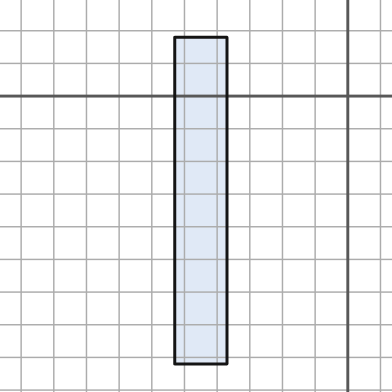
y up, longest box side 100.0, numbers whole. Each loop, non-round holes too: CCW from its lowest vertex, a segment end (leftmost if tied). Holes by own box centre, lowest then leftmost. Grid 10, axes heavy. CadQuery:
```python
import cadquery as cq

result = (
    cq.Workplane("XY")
    .moveTo(-53.0, -82.0)
    .lineTo(-37.0, -82.0)
    .lineTo(-37.0, 18.0)
    .lineTo(-53.0, 18.0)
    .close()
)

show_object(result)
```